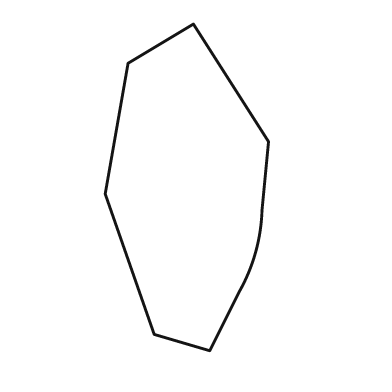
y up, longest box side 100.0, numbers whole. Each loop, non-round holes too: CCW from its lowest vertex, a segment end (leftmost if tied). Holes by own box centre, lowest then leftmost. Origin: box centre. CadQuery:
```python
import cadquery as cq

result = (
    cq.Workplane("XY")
    .moveTo(7.0, -50.0)
    .lineTo(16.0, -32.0)
    .threePointArc((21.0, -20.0), (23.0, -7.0))
    .lineTo(25.0, 14.0)
    .lineTo(2.0, 50.0)
    .lineTo(-18.0, 38.0)
    .lineTo(-25.0, -2.0)
    .lineTo(-10.0, -45.0)
    .close()
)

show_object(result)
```